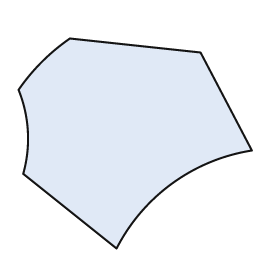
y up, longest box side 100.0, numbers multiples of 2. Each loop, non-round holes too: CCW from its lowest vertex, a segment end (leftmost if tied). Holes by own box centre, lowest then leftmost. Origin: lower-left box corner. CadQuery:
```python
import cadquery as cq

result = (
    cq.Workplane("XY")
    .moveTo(42.0, 0.0)
    .threePointArc((66.0, 28.0), (100.0, 42.0))
    .lineTo(78.0, 84.0)
    .lineTo(22.0, 90.0)
    .threePointArc((10.0, 80.0), (0.0, 68.0))
    .threePointArc((4.0, 50.0), (2.0, 32.0))
    .close()
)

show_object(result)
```